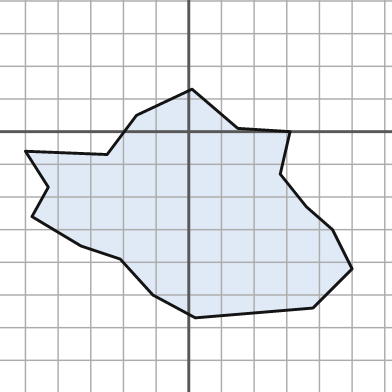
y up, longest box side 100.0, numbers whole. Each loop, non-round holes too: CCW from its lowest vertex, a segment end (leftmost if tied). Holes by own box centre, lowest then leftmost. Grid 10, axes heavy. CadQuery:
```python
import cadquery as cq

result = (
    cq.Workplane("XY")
    .moveTo(2.0, -57.0)
    .lineTo(38.0, -54.0)
    .lineTo(50.0, -42.0)
    .lineTo(44.0, -30.0)
    .lineTo(36.0, -23.0)
    .lineTo(28.0, -13.0)
    .lineTo(31.0, 0.0)
    .lineTo(15.0, 1.0)
    .lineTo(1.0, 13.0)
    .lineTo(-16.0, 5.0)
    .lineTo(-25.0, -7.0)
    .lineTo(-50.0, -6.0)
    .lineTo(-43.0, -17.0)
    .lineTo(-48.0, -26.0)
    .lineTo(-33.0, -35.0)
    .lineTo(-21.0, -39.0)
    .lineTo(-11.0, -50.0)
    .close()
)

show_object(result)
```